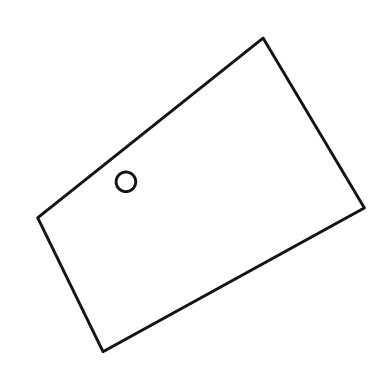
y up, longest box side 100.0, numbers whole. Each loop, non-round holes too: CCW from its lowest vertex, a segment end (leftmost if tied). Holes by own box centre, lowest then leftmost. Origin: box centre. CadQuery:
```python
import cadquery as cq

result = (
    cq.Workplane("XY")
    .moveTo(-30.0, -48.0)
    .lineTo(50.0, -4.0)
    .lineTo(19.0, 48.0)
    .lineTo(-50.0, -7.0)
    .close()
    .moveTo(-23.0, 4.0)
    .circle(3.0)
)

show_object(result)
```